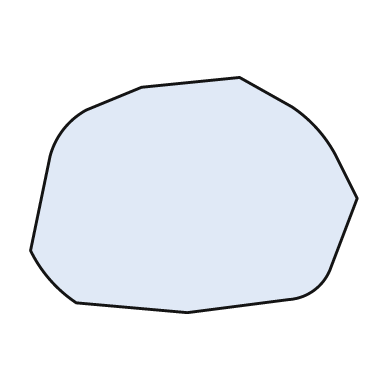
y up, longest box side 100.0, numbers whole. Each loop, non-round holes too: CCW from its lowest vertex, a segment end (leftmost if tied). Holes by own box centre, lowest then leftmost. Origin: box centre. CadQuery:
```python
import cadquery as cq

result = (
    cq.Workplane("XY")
    .moveTo(-2.0, -36.0)
    .lineTo(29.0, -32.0)
    .threePointArc((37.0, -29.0), (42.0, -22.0))
    .lineTo(50.0, -1.0)
    .lineTo(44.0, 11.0)
    .threePointArc((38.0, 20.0), (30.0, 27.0))
    .lineTo(14.0, 36.0)
    .lineTo(-16.0, 33.0)
    .lineTo(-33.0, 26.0)
    .threePointArc((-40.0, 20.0), (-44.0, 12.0))
    .lineTo(-50.0, -17.0)
    .threePointArc((-44.0, -26.0), (-36.0, -33.0))
    .close()
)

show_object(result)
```